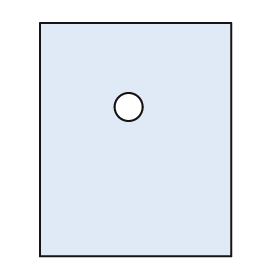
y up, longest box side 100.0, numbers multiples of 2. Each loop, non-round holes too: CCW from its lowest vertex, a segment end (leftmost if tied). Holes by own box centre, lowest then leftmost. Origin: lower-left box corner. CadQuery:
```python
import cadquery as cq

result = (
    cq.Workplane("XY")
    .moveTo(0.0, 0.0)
    .lineTo(82.0, 0.0)
    .lineTo(82.0, 100.0)
    .lineTo(0.0, 100.0)
    .close()
    .moveTo(38.0, 64.0)
    .circle(6.0)
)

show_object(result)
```